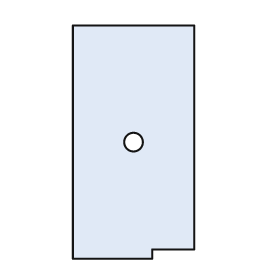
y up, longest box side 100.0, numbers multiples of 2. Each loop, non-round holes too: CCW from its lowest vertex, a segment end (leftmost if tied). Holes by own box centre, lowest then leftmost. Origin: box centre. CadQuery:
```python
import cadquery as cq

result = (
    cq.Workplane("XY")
    .moveTo(-26.0, -50.0)
    .lineTo(8.0, -50.0)
    .lineTo(8.0, -46.0)
    .lineTo(26.0, -46.0)
    .lineTo(26.0, 50.0)
    .lineTo(-26.0, 50.0)
    .close()
    .moveTo(0.0, 0.0)
    .circle(4.0)
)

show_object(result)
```